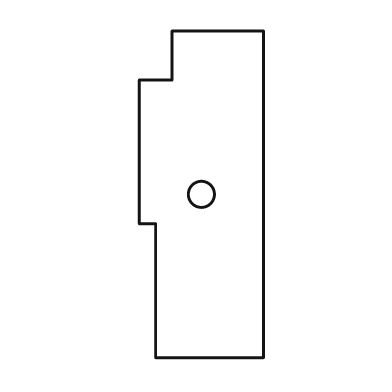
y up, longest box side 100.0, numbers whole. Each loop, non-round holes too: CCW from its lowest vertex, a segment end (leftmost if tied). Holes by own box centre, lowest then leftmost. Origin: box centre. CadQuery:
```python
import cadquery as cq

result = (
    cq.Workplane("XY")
    .moveTo(-14.0, -50.0)
    .lineTo(19.0, -50.0)
    .lineTo(19.0, 50.0)
    .lineTo(-9.0, 50.0)
    .lineTo(-9.0, 35.0)
    .lineTo(-19.0, 35.0)
    .lineTo(-19.0, -9.0)
    .lineTo(-14.0, -9.0)
    .close()
    .moveTo(0.0, 0.0)
    .circle(4.0)
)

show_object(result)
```